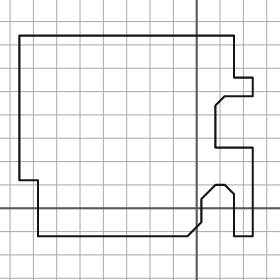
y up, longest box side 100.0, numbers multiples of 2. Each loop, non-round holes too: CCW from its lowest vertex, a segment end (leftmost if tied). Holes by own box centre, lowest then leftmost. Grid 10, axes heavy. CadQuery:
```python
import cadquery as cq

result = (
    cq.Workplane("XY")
    .moveTo(-68.0, -12.0)
    .lineTo(-4.0, -12.0)
    .lineTo(2.0, -6.0)
    .lineTo(2.0, 4.0)
    .lineTo(8.0, 10.0)
    .lineTo(12.0, 10.0)
    .lineTo(16.0, 6.0)
    .lineTo(16.0, -12.0)
    .lineTo(24.0, -12.0)
    .lineTo(24.0, 26.0)
    .lineTo(8.0, 26.0)
    .lineTo(8.0, 44.0)
    .lineTo(12.0, 48.0)
    .lineTo(24.0, 48.0)
    .lineTo(24.0, 56.0)
    .lineTo(16.0, 56.0)
    .lineTo(16.0, 74.0)
    .lineTo(-76.0, 74.0)
    .lineTo(-76.0, 12.0)
    .lineTo(-68.0, 12.0)
    .close()
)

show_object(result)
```